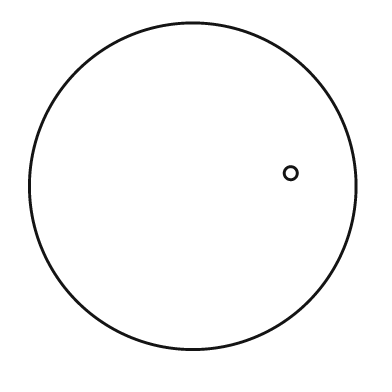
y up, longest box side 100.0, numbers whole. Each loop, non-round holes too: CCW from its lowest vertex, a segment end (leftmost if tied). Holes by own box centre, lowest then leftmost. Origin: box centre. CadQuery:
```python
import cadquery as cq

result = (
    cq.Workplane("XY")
    .moveTo(0.0, 0.0)
    .circle(50.0)
    .moveTo(30.0, 4.0)
    .circle(2.0)
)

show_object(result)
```